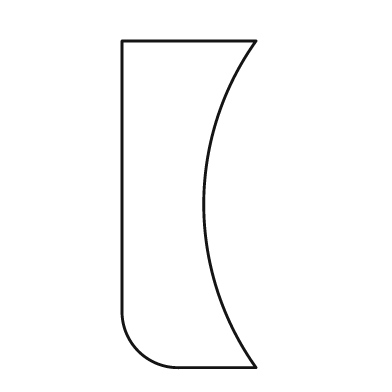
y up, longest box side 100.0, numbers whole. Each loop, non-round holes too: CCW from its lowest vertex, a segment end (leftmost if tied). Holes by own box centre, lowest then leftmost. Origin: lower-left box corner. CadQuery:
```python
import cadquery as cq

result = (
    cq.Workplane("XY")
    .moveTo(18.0, 0.0)
    .lineTo(41.0, 0.0)
    .threePointArc((25.0, 50.0), (41.0, 100.0))
    .lineTo(0.0, 100.0)
    .lineTo(0.0, 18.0)
    .threePointArc((5.0, 5.0), (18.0, 0.0))
    .close()
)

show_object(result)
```